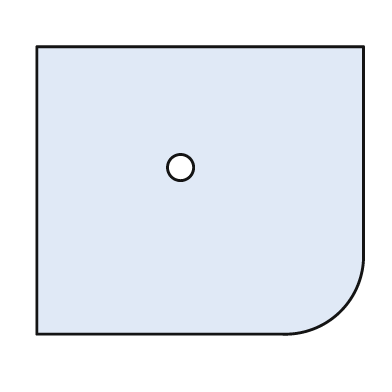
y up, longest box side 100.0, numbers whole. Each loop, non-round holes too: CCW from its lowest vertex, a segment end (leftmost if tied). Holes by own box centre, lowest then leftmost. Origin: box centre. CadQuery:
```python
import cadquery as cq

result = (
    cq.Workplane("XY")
    .moveTo(-50.0, -44.0)
    .lineTo(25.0, -44.0)
    .threePointArc((43.0, -37.0), (50.0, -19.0))
    .lineTo(50.0, 44.0)
    .lineTo(-50.0, 44.0)
    .close()
    .moveTo(-6.0, 7.0)
    .circle(4.0)
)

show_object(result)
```